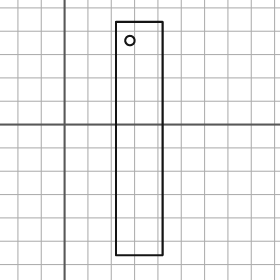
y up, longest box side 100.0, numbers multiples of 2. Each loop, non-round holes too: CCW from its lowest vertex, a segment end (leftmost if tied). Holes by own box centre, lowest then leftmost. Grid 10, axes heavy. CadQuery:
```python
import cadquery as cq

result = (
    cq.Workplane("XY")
    .moveTo(22.0, -56.0)
    .lineTo(42.0, -56.0)
    .lineTo(42.0, 44.0)
    .lineTo(22.0, 44.0)
    .close()
    .moveTo(28.0, 36.0)
    .circle(2.0)
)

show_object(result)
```